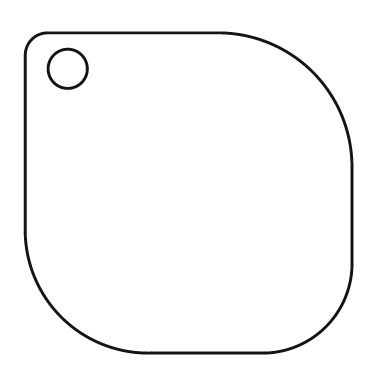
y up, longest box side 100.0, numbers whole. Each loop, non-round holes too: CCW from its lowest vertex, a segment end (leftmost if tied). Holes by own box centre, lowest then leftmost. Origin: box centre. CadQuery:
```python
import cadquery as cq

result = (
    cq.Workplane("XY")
    .moveTo(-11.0, -49.0)
    .lineTo(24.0, -49.0)
    .threePointArc((42.0, -41.0), (50.0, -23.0))
    .lineTo(50.0, 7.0)
    .threePointArc((38.0, 37.0), (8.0, 49.0))
    .lineTo(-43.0, 49.0)
    .threePointArc((-48.0, 47.0), (-50.0, 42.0))
    .lineTo(-50.0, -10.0)
    .threePointArc((-39.0, -38.0), (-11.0, -49.0))
    .close()
    .moveTo(-37.0, 38.0)
    .circle(6.0)
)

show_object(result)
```